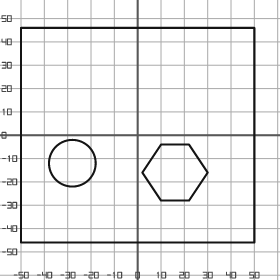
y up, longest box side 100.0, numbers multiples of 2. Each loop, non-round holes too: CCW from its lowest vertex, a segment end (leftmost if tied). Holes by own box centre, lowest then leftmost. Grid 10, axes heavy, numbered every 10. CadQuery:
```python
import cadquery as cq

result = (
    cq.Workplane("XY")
    .moveTo(-50.0, -46.0)
    .lineTo(50.0, -46.0)
    .lineTo(50.0, 46.0)
    .lineTo(-50.0, 46.0)
    .close()
    .moveTo(10.0, -28.0)
    .lineTo(22.0, -28.0)
    .lineTo(30.0, -16.0)
    .lineTo(22.0, -4.0)
    .lineTo(10.0, -4.0)
    .lineTo(2.0, -16.0)
    .close()
    .moveTo(-28.0, -12.0)
    .circle(10.0)
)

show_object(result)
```